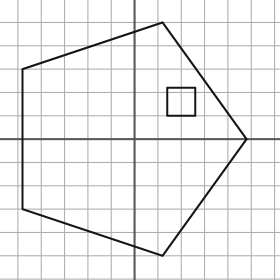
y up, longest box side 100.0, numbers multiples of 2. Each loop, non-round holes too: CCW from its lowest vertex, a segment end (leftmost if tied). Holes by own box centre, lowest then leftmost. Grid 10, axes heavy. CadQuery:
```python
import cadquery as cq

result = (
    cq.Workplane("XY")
    .moveTo(12.0, -50.0)
    .lineTo(48.0, 0.0)
    .lineTo(12.0, 50.0)
    .lineTo(-48.0, 30.0)
    .lineTo(-48.0, -30.0)
    .close()
    .moveTo(14.0, 10.0)
    .lineTo(26.0, 10.0)
    .lineTo(26.0, 22.0)
    .lineTo(14.0, 22.0)
    .close()
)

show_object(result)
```